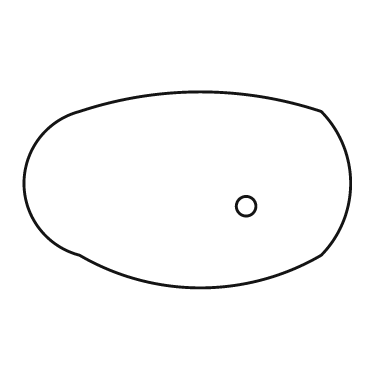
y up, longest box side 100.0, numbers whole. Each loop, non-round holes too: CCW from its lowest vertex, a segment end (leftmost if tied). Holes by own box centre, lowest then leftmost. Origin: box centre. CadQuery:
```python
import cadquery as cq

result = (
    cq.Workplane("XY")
    .moveTo(-33.0, -20.0)
    .threePointArc((4.0, -30.0), (41.0, -20.0))
    .threePointArc((50.0, 2.0), (41.0, 24.0))
    .threePointArc((4.0, 30.0), (-33.0, 24.0))
    .threePointArc((-50.0, 2.0), (-33.0, -20.0))
    .close()
    .moveTo(18.0, -5.0)
    .circle(3.0)
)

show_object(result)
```